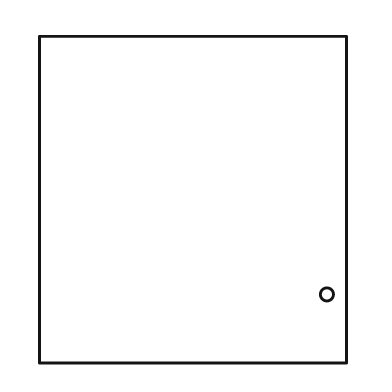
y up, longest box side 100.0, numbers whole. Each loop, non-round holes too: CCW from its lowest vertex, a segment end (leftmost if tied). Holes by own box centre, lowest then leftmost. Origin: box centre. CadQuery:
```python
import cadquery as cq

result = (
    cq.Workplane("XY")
    .moveTo(-47.0, -50.0)
    .lineTo(47.0, -50.0)
    .lineTo(47.0, 50.0)
    .lineTo(-47.0, 50.0)
    .close()
    .moveTo(41.0, -29.0)
    .circle(2.0)
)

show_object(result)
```